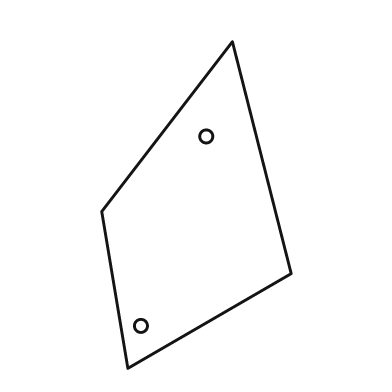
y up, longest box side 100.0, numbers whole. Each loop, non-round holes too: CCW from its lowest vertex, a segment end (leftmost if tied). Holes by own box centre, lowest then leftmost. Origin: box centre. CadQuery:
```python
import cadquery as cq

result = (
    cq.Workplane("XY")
    .moveTo(-21.0, -50.0)
    .lineTo(29.0, -21.0)
    .lineTo(11.0, 50.0)
    .lineTo(-29.0, -2.0)
    .close()
    .moveTo(-17.0, -37.0)
    .circle(2.0)
    .moveTo(3.0, 21.0)
    .circle(2.0)
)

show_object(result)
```